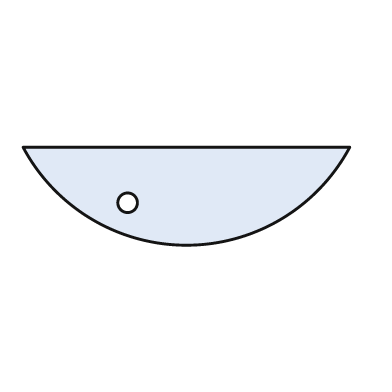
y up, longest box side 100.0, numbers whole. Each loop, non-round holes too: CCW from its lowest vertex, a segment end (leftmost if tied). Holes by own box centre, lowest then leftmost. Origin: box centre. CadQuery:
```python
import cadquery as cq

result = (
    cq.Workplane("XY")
    .moveTo(-50.0, 15.0)
    .threePointArc((0.0, -15.0), (50.0, 15.0))
    .close()
    .moveTo(-18.0, -2.0)
    .circle(3.0)
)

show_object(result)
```